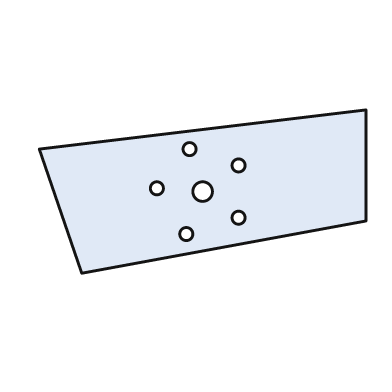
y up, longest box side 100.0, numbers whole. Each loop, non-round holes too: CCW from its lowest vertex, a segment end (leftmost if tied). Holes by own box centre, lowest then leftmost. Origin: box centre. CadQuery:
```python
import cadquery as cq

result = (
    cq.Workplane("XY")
    .moveTo(-37.0, -25.0)
    .lineTo(50.0, -9.0)
    .lineTo(50.0, 25.0)
    .lineTo(-50.0, 13.0)
    .close()
    .moveTo(-5.0, -13.0)
    .circle(2.0)
    .moveTo(11.0, -8.0)
    .circle(2.0)
    .moveTo(0.0, 0.0)
    .circle(3.0)
    .moveTo(-14.0, 1.0)
    .circle(2.0)
    .moveTo(11.0, 8.0)
    .circle(2.0)
    .moveTo(-4.0, 13.0)
    .circle(2.0)
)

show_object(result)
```